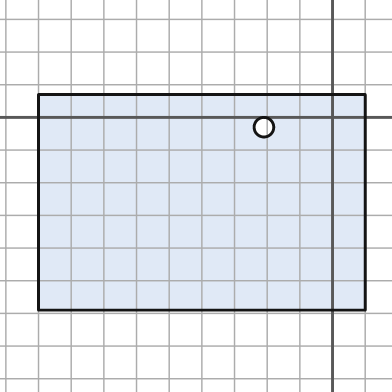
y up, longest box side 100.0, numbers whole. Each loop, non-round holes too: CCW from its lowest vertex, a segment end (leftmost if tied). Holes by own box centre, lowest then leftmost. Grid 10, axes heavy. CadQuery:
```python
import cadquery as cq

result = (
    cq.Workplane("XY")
    .moveTo(-90.0, -59.0)
    .lineTo(10.0, -59.0)
    .lineTo(10.0, 7.0)
    .lineTo(-90.0, 7.0)
    .close()
    .moveTo(-21.0, -3.0)
    .circle(3.0)
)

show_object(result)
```